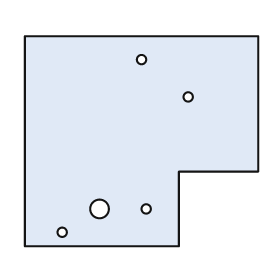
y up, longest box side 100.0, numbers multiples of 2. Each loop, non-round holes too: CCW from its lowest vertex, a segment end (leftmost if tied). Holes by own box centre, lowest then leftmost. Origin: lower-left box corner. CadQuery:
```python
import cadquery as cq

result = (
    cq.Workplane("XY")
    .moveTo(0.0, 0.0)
    .lineTo(66.0, 0.0)
    .lineTo(66.0, 32.0)
    .lineTo(100.0, 32.0)
    .lineTo(100.0, 90.0)
    .lineTo(0.0, 90.0)
    .close()
    .moveTo(16.0, 6.0)
    .circle(2.0)
    .moveTo(32.0, 16.0)
    .circle(4.0)
    .moveTo(52.0, 16.0)
    .circle(2.0)
    .moveTo(70.0, 64.0)
    .circle(2.0)
    .moveTo(50.0, 80.0)
    .circle(2.0)
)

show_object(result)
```